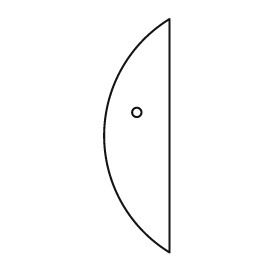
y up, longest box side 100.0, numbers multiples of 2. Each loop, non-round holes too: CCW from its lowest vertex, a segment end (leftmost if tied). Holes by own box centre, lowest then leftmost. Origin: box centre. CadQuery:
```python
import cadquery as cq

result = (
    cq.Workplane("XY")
    .moveTo(14.0, -50.0)
    .lineTo(14.0, 50.0)
    .threePointArc((-14.0, 0.0), (14.0, -50.0))
    .close()
    .moveTo(0.0, 10.0)
    .circle(2.0)
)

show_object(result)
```